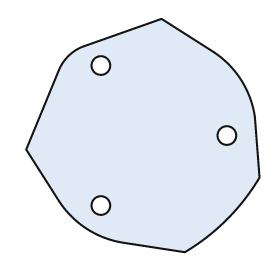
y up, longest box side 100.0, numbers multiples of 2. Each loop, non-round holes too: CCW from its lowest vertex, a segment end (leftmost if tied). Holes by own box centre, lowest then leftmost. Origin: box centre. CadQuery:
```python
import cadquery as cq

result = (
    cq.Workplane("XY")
    .moveTo(18.0, -50.0)
    .threePointArc((36.0, -36.0), (50.0, -18.0))
    .lineTo(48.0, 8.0)
    .threePointArc((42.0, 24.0), (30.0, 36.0))
    .lineTo(8.0, 50.0)
    .lineTo(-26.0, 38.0)
    .threePointArc((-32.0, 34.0), (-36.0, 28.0))
    .lineTo(-50.0, -6.0)
    .lineTo(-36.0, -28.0)
    .threePointArc((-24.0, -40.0), (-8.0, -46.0))
    .close()
    .moveTo(-18.0, -30.0)
    .circle(4.0)
    .moveTo(36.0, 0.0)
    .circle(4.0)
    .moveTo(-18.0, 30.0)
    .circle(4.0)
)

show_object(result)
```